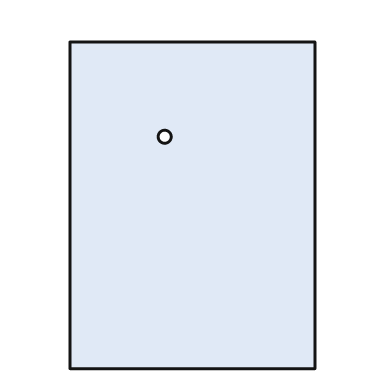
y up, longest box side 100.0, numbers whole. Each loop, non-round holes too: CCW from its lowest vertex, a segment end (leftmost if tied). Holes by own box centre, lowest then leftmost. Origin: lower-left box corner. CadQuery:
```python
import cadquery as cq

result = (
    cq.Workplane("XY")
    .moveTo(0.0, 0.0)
    .lineTo(75.0, 0.0)
    .lineTo(75.0, 100.0)
    .lineTo(0.0, 100.0)
    .close()
    .moveTo(29.0, 71.0)
    .circle(2.0)
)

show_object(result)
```